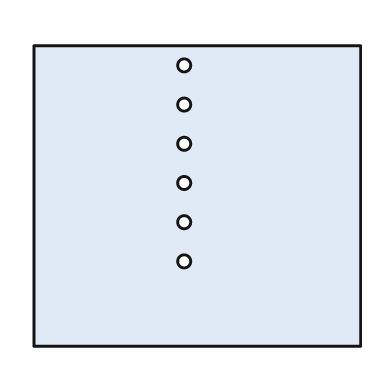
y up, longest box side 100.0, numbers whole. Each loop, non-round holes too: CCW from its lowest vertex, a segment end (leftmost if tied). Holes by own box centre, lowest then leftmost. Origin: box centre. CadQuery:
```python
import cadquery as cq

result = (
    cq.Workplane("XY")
    .moveTo(-50.0, -46.0)
    .lineTo(50.0, -46.0)
    .lineTo(50.0, 46.0)
    .lineTo(-50.0, 46.0)
    .close()
    .moveTo(-4.0, -20.0)
    .circle(2.0)
    .moveTo(-4.0, -8.0)
    .circle(2.0)
    .moveTo(-4.0, 4.0)
    .circle(2.0)
    .moveTo(-4.0, 16.0)
    .circle(2.0)
    .moveTo(-4.0, 28.0)
    .circle(2.0)
    .moveTo(-4.0, 40.0)
    .circle(2.0)
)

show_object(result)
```